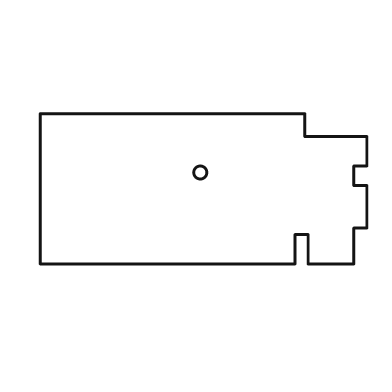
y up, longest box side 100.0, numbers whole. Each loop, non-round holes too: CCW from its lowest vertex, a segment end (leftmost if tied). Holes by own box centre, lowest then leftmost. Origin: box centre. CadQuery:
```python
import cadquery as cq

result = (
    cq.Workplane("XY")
    .moveTo(-50.0, -23.0)
    .lineTo(28.0, -23.0)
    .lineTo(28.0, -14.0)
    .lineTo(32.0, -14.0)
    .lineTo(32.0, -23.0)
    .lineTo(46.0, -23.0)
    .lineTo(46.0, -12.0)
    .lineTo(50.0, -12.0)
    .lineTo(50.0, 1.0)
    .lineTo(46.0, 1.0)
    .lineTo(46.0, 7.0)
    .lineTo(50.0, 7.0)
    .lineTo(50.0, 16.0)
    .lineTo(31.0, 16.0)
    .lineTo(31.0, 23.0)
    .lineTo(-50.0, 23.0)
    .close()
    .moveTo(-1.0, 5.0)
    .circle(2.0)
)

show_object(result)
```